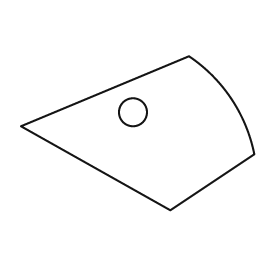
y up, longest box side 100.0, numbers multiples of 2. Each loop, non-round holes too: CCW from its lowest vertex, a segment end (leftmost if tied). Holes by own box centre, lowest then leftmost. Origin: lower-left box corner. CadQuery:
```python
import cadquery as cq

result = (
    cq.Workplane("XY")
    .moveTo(64.0, 0.0)
    .lineTo(100.0, 24.0)
    .threePointArc((90.0, 48.0), (72.0, 66.0))
    .lineTo(0.0, 36.0)
    .close()
    .moveTo(48.0, 42.0)
    .circle(6.0)
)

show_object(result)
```